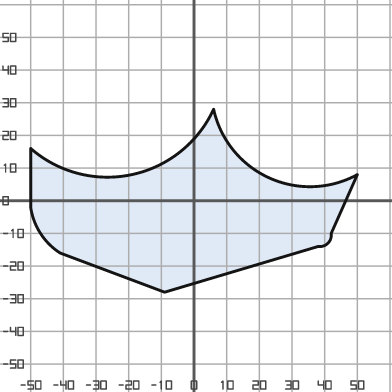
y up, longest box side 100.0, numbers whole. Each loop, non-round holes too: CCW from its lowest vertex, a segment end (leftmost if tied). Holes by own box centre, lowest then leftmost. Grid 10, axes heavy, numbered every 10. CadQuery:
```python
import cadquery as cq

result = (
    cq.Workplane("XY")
    .moveTo(-9.0, -28.0)
    .lineTo(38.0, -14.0)
    .threePointArc((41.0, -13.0), (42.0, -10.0))
    .lineTo(50.0, 8.0)
    .threePointArc((23.0, 7.0), (6.0, 28.0))
    .threePointArc((-19.0, 8.0), (-50.0, 16.0))
    .lineTo(-50.0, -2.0)
    .threePointArc((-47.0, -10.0), (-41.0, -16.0))
    .close()
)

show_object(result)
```